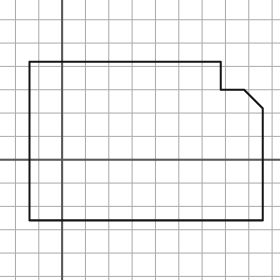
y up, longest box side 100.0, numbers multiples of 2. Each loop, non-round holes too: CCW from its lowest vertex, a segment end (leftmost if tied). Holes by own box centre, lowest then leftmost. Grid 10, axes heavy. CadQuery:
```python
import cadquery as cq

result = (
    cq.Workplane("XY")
    .moveTo(-14.0, -26.0)
    .lineTo(86.0, -26.0)
    .lineTo(86.0, 22.0)
    .lineTo(78.0, 30.0)
    .lineTo(68.0, 30.0)
    .lineTo(68.0, 42.0)
    .lineTo(-14.0, 42.0)
    .close()
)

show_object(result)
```